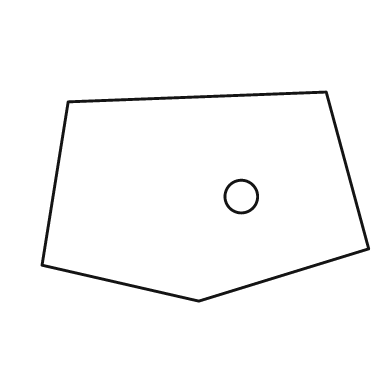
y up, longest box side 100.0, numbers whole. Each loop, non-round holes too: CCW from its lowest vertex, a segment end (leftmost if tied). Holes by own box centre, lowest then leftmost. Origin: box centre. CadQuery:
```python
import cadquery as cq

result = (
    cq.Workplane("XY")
    .moveTo(-2.0, -32.0)
    .lineTo(50.0, -16.0)
    .lineTo(37.0, 32.0)
    .lineTo(-42.0, 29.0)
    .lineTo(-50.0, -21.0)
    .close()
    .moveTo(11.0, 0.0)
    .circle(5.0)
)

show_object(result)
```